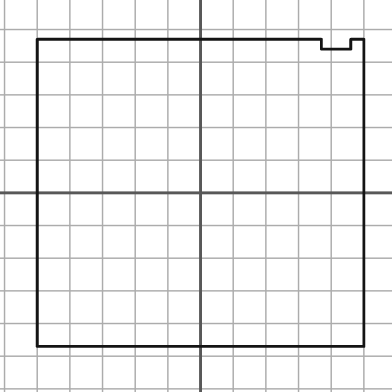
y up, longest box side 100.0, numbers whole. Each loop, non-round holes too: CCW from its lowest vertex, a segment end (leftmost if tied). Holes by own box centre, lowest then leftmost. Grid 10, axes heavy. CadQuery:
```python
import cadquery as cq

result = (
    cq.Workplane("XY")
    .moveTo(-50.0, -47.0)
    .lineTo(50.0, -47.0)
    .lineTo(50.0, 47.0)
    .lineTo(46.0, 47.0)
    .lineTo(46.0, 44.0)
    .lineTo(37.0, 44.0)
    .lineTo(37.0, 47.0)
    .lineTo(-50.0, 47.0)
    .close()
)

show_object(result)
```